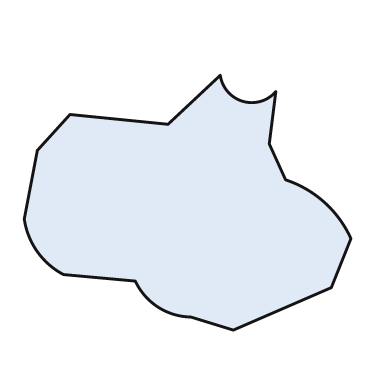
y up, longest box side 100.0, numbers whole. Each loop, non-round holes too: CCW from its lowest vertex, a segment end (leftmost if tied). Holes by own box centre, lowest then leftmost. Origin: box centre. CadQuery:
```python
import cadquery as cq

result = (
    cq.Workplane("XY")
    .moveTo(14.0, -39.0)
    .lineTo(44.0, -26.0)
    .lineTo(50.0, -11.0)
    .threePointArc((42.0, 0.0), (30.0, 7.0))
    .lineTo(25.0, 18.0)
    .lineTo(27.0, 34.0)
    .threePointArc((17.0, 31.0), (10.0, 39.0))
    .lineTo(-6.0, 24.0)
    .lineTo(-36.0, 27.0)
    .lineTo(-46.0, 16.0)
    .lineTo(-50.0, -5.0)
    .threePointArc((-46.0, -15.0), (-38.0, -22.0))
    .lineTo(-16.0, -24.0)
    .threePointArc((-9.0, -32.0), (1.0, -35.0))
    .close()
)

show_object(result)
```